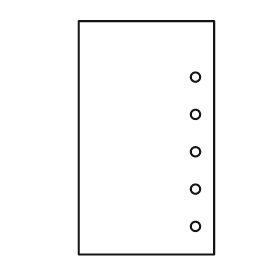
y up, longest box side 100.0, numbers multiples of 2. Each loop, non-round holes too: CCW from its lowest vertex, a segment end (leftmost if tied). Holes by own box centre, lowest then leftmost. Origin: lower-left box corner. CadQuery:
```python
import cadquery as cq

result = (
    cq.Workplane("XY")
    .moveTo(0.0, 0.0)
    .lineTo(58.0, 0.0)
    .lineTo(58.0, 100.0)
    .lineTo(0.0, 100.0)
    .close()
    .moveTo(50.0, 12.0)
    .circle(2.0)
    .moveTo(50.0, 28.0)
    .circle(2.0)
    .moveTo(50.0, 44.0)
    .circle(2.0)
    .moveTo(50.0, 60.0)
    .circle(2.0)
    .moveTo(50.0, 76.0)
    .circle(2.0)
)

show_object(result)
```